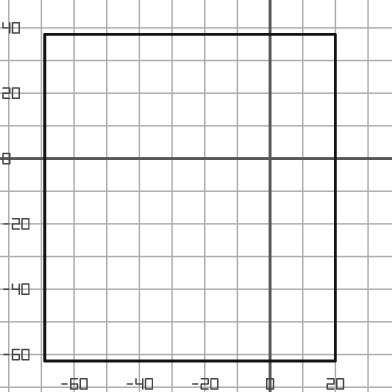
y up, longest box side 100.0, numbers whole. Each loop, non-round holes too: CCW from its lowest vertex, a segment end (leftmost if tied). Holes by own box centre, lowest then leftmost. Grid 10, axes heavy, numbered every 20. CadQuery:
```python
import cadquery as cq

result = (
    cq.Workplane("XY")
    .moveTo(-69.0, -62.0)
    .lineTo(20.0, -62.0)
    .lineTo(20.0, 38.0)
    .lineTo(-69.0, 38.0)
    .close()
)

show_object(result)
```